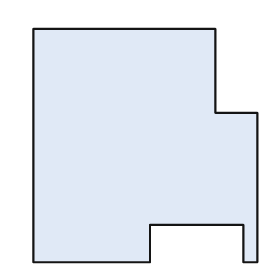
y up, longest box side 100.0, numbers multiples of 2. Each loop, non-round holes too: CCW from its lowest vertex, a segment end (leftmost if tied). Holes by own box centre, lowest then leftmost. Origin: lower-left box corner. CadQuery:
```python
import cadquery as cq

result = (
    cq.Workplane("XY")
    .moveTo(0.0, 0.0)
    .lineTo(50.0, 0.0)
    .lineTo(50.0, 16.0)
    .lineTo(90.0, 16.0)
    .lineTo(90.0, 0.0)
    .lineTo(96.0, 0.0)
    .lineTo(96.0, 64.0)
    .lineTo(78.0, 64.0)
    .lineTo(78.0, 100.0)
    .lineTo(0.0, 100.0)
    .close()
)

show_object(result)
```